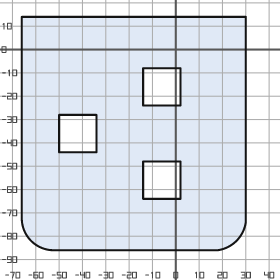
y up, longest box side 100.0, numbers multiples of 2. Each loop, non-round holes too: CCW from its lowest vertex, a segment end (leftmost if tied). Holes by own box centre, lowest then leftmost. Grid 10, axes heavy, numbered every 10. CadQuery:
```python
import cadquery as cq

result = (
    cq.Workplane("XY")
    .moveTo(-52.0, -86.0)
    .lineTo(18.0, -86.0)
    .threePointArc((26.0, -82.0), (30.0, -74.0))
    .lineTo(30.0, 14.0)
    .lineTo(-66.0, 14.0)
    .lineTo(-66.0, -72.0)
    .threePointArc((-62.0, -82.0), (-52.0, -86.0))
    .close()
    .moveTo(-14.0, -64.0)
    .lineTo(2.0, -64.0)
    .lineTo(2.0, -48.0)
    .lineTo(-14.0, -48.0)
    .close()
    .moveTo(-50.0, -44.0)
    .lineTo(-34.0, -44.0)
    .lineTo(-34.0, -28.0)
    .lineTo(-50.0, -28.0)
    .close()
    .moveTo(-14.0, -24.0)
    .lineTo(2.0, -24.0)
    .lineTo(2.0, -8.0)
    .lineTo(-14.0, -8.0)
    .close()
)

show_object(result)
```